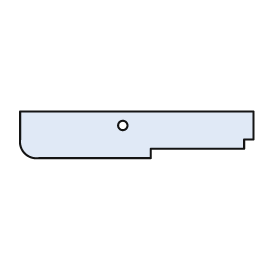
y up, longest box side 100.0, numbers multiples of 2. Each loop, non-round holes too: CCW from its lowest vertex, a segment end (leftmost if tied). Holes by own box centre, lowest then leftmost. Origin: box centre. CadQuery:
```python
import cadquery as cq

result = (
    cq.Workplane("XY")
    .moveTo(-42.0, -10.0)
    .lineTo(6.0, -10.0)
    .lineTo(6.0, -6.0)
    .lineTo(46.0, -6.0)
    .lineTo(46.0, -2.0)
    .lineTo(50.0, -2.0)
    .lineTo(50.0, 10.0)
    .lineTo(-50.0, 10.0)
    .lineTo(-50.0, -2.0)
    .threePointArc((-48.0, -8.0), (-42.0, -10.0))
    .close()
    .moveTo(-6.0, 4.0)
    .circle(2.0)
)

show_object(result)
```